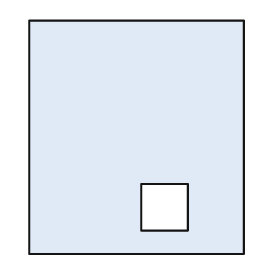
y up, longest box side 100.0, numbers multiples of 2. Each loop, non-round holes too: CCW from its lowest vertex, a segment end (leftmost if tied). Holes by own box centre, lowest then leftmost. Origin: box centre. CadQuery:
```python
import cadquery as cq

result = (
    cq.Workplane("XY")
    .moveTo(-46.0, -50.0)
    .lineTo(46.0, -50.0)
    .lineTo(46.0, 50.0)
    .lineTo(-46.0, 50.0)
    .close()
    .moveTo(2.0, -40.0)
    .lineTo(22.0, -40.0)
    .lineTo(22.0, -20.0)
    .lineTo(2.0, -20.0)
    .close()
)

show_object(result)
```